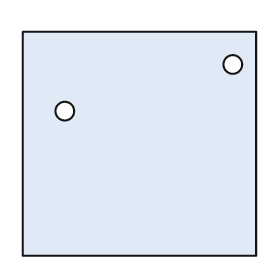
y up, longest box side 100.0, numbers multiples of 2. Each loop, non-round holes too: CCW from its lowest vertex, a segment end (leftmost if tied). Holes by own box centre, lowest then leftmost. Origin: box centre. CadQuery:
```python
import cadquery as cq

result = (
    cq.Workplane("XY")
    .moveTo(-50.0, -48.0)
    .lineTo(50.0, -48.0)
    .lineTo(50.0, 48.0)
    .lineTo(-50.0, 48.0)
    .close()
    .moveTo(-32.0, 14.0)
    .circle(4.0)
    .moveTo(40.0, 34.0)
    .circle(4.0)
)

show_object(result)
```